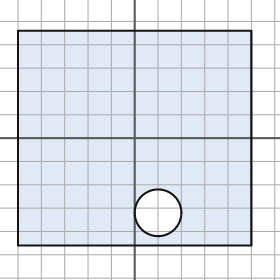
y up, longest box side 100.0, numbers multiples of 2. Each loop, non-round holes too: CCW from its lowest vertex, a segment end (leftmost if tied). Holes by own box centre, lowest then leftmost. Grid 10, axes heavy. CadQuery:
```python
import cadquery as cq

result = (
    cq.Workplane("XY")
    .moveTo(-50.0, -46.0)
    .lineTo(50.0, -46.0)
    .lineTo(50.0, 46.0)
    .lineTo(-50.0, 46.0)
    .close()
    .moveTo(10.0, -32.0)
    .circle(10.0)
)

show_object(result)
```